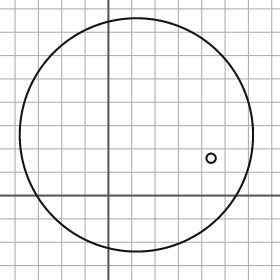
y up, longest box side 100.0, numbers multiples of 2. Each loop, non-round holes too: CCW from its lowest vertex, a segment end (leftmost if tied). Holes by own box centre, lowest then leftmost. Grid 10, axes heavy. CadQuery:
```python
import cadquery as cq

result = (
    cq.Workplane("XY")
    .moveTo(12.0, 26.0)
    .circle(50.0)
    .moveTo(44.0, 16.0)
    .circle(2.0)
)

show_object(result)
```